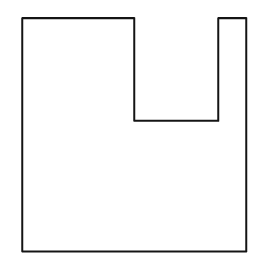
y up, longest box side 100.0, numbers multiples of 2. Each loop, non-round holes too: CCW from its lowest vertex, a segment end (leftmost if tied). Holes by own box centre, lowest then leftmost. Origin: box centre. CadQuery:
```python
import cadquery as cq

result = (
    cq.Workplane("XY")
    .moveTo(-48.0, -50.0)
    .lineTo(48.0, -50.0)
    .lineTo(48.0, 50.0)
    .lineTo(36.0, 50.0)
    .lineTo(36.0, 6.0)
    .lineTo(0.0, 6.0)
    .lineTo(0.0, 50.0)
    .lineTo(-48.0, 50.0)
    .close()
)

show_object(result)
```